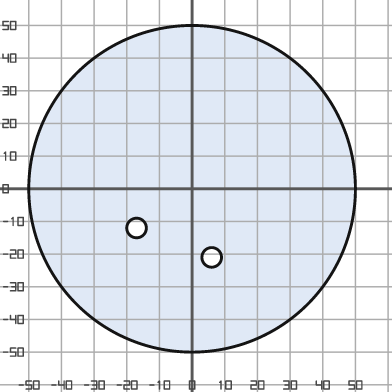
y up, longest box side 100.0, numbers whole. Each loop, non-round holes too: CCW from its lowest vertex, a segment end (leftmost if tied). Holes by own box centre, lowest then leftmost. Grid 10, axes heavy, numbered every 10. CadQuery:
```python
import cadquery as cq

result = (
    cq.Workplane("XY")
    .moveTo(0.0, 0.0)
    .circle(50.0)
    .moveTo(6.0, -21.0)
    .circle(3.0)
    .moveTo(-17.0, -12.0)
    .circle(3.0)
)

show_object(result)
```